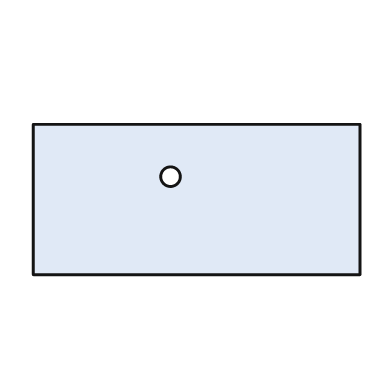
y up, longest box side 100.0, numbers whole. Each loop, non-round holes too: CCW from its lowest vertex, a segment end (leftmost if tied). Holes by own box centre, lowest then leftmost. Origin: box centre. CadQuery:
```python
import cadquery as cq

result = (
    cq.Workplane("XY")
    .moveTo(-50.0, -23.0)
    .lineTo(50.0, -23.0)
    .lineTo(50.0, 23.0)
    .lineTo(-50.0, 23.0)
    .close()
    .moveTo(-8.0, 7.0)
    .circle(3.0)
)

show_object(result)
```